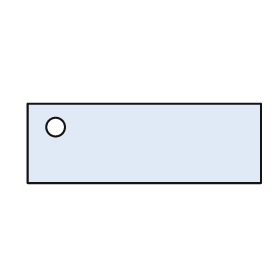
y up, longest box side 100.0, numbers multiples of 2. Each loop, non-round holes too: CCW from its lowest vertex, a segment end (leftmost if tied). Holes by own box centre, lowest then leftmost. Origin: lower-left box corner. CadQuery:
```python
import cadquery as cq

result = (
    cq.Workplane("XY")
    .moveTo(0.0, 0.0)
    .lineTo(100.0, 0.0)
    .lineTo(100.0, 34.0)
    .lineTo(0.0, 34.0)
    .close()
    .moveTo(12.0, 24.0)
    .circle(4.0)
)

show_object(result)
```